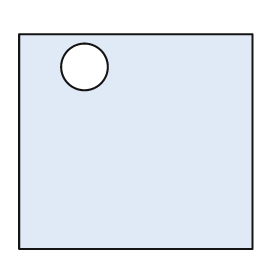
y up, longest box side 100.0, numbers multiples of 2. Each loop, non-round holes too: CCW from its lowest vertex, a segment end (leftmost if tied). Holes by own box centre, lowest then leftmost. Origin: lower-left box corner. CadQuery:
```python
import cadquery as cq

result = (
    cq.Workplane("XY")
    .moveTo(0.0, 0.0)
    .lineTo(100.0, 0.0)
    .lineTo(100.0, 92.0)
    .lineTo(0.0, 92.0)
    .close()
    .moveTo(28.0, 78.0)
    .circle(10.0)
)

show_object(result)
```